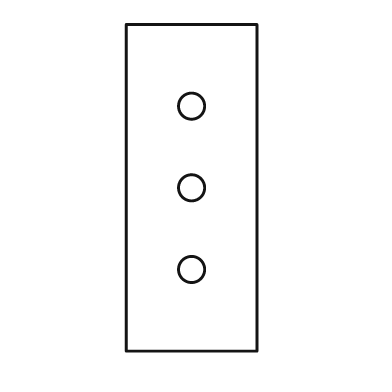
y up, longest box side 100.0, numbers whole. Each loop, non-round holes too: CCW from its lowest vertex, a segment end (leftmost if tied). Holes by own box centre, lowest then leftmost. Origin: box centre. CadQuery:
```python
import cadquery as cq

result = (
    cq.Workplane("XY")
    .moveTo(-20.0, -50.0)
    .lineTo(20.0, -50.0)
    .lineTo(20.0, 50.0)
    .lineTo(-20.0, 50.0)
    .close()
    .moveTo(0.0, -25.0)
    .circle(4.0)
    .moveTo(0.0, 0.0)
    .circle(4.0)
    .moveTo(0.0, 25.0)
    .circle(4.0)
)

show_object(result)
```